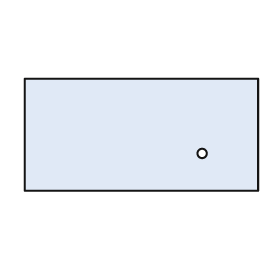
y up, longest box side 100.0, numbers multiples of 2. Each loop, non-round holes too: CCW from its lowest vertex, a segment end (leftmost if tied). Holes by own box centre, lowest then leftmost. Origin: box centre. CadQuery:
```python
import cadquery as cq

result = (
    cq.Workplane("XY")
    .moveTo(-50.0, -24.0)
    .lineTo(50.0, -24.0)
    .lineTo(50.0, 24.0)
    .lineTo(-50.0, 24.0)
    .close()
    .moveTo(26.0, -8.0)
    .circle(2.0)
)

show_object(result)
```